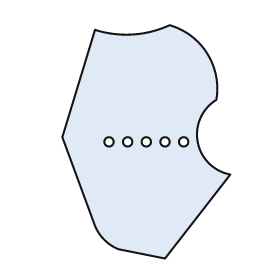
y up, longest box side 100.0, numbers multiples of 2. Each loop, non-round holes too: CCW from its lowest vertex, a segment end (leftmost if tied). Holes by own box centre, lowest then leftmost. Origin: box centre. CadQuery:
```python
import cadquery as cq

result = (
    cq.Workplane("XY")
    .moveTo(8.0, -50.0)
    .lineTo(36.0, -14.0)
    .threePointArc((22.0, 0.0), (30.0, 18.0))
    .threePointArc((26.0, 38.0), (10.0, 50.0))
    .threePointArc((-6.0, 46.0), (-22.0, 48.0))
    .lineTo(-36.0, 2.0)
    .lineTo(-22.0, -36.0)
    .threePointArc((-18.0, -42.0), (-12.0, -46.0))
    .close()
    .moveTo(-16.0, 0.0)
    .circle(2.0)
    .moveTo(-8.0, 0.0)
    .circle(2.0)
    .moveTo(0.0, 0.0)
    .circle(2.0)
    .moveTo(8.0, 0.0)
    .circle(2.0)
    .moveTo(16.0, 0.0)
    .circle(2.0)
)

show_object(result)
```